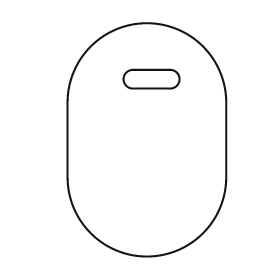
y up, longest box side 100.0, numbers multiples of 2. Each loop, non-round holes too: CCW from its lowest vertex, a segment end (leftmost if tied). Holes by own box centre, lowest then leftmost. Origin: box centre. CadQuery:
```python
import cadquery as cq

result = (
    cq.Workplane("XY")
    .moveTo(-34.0, -16.0)
    .threePointArc((0.0, -50.0), (34.0, -16.0))
    .lineTo(34.0, 16.0)
    .threePointArc((0.0, 50.0), (-34.0, 16.0))
    .close()
    .moveTo(-6.0, 22.0)
    .lineTo(10.0, 22.0)
    .threePointArc((14.0, 26.0), (10.0, 30.0))
    .lineTo(-6.0, 30.0)
    .threePointArc((-10.0, 26.0), (-6.0, 22.0))
    .close()
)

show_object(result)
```